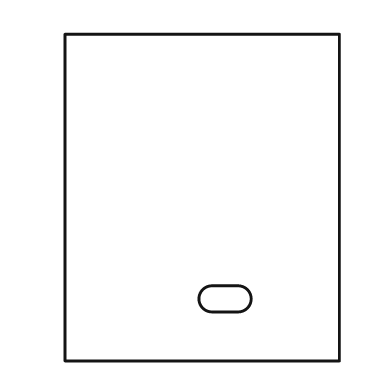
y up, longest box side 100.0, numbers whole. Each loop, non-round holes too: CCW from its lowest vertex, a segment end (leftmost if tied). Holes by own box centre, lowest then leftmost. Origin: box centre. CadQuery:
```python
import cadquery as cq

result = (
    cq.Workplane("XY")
    .moveTo(-42.0, -50.0)
    .lineTo(42.0, -50.0)
    .lineTo(42.0, 50.0)
    .lineTo(-42.0, 50.0)
    .close()
    .moveTo(3.0, -35.0)
    .lineTo(11.0, -35.0)
    .threePointArc((15.0, -31.0), (11.0, -27.0))
    .lineTo(3.0, -27.0)
    .threePointArc((-1.0, -31.0), (3.0, -35.0))
    .close()
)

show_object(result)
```